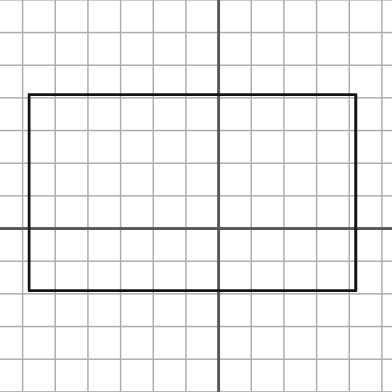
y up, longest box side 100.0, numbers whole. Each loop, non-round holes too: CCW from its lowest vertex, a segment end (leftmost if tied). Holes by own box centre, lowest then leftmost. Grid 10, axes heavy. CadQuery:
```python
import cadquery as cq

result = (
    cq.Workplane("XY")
    .moveTo(-58.0, -19.0)
    .lineTo(42.0, -19.0)
    .lineTo(42.0, 41.0)
    .lineTo(-58.0, 41.0)
    .close()
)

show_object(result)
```